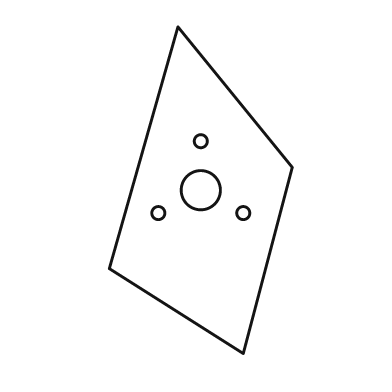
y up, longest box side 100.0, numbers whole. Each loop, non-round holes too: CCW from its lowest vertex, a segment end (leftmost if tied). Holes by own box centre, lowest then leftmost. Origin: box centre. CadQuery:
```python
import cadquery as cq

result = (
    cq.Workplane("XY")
    .moveTo(13.0, -50.0)
    .lineTo(28.0, 7.0)
    .lineTo(-7.0, 50.0)
    .lineTo(-28.0, -24.0)
    .close()
    .moveTo(-13.0, -7.0)
    .circle(2.0)
    .moveTo(13.0, -7.0)
    .circle(2.0)
    .moveTo(0.0, 0.0)
    .circle(6.0)
    .moveTo(0.0, 15.0)
    .circle(2.0)
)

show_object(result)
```